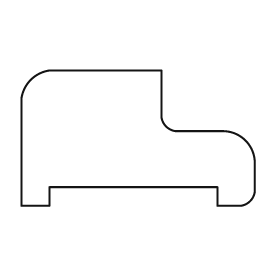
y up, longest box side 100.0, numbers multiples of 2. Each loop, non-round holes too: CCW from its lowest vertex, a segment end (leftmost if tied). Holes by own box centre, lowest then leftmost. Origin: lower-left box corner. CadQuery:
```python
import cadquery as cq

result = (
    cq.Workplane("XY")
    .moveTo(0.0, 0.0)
    .lineTo(12.0, 0.0)
    .lineTo(12.0, 8.0)
    .lineTo(84.0, 8.0)
    .lineTo(84.0, 0.0)
    .lineTo(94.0, 0.0)
    .threePointArc((98.0, 2.0), (100.0, 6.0))
    .lineTo(100.0, 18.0)
    .threePointArc((96.0, 28.0), (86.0, 32.0))
    .lineTo(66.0, 32.0)
    .threePointArc((62.0, 34.0), (60.0, 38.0))
    .lineTo(60.0, 58.0)
    .lineTo(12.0, 58.0)
    .threePointArc((4.0, 54.0), (0.0, 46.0))
    .close()
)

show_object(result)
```